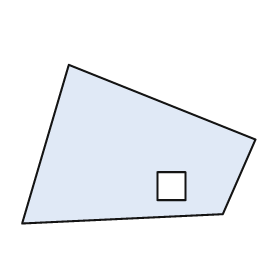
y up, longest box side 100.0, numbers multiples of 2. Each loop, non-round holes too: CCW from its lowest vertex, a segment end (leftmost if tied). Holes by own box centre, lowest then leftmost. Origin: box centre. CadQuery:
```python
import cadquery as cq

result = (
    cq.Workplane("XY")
    .moveTo(-50.0, -34.0)
    .lineTo(36.0, -30.0)
    .lineTo(50.0, 2.0)
    .lineTo(-30.0, 34.0)
    .close()
    .moveTo(8.0, -24.0)
    .lineTo(20.0, -24.0)
    .lineTo(20.0, -12.0)
    .lineTo(8.0, -12.0)
    .close()
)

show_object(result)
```